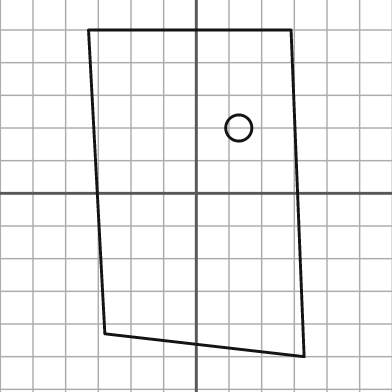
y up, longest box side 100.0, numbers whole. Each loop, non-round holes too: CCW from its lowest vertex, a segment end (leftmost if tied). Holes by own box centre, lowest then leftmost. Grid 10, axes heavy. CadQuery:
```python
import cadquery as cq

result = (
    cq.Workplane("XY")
    .moveTo(33.0, -50.0)
    .lineTo(29.0, 50.0)
    .lineTo(-33.0, 50.0)
    .lineTo(-28.0, -43.0)
    .close()
    .moveTo(13.0, 20.0)
    .circle(4.0)
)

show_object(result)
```